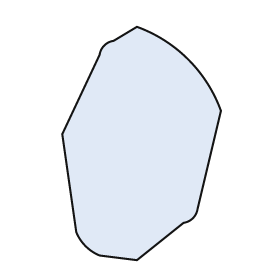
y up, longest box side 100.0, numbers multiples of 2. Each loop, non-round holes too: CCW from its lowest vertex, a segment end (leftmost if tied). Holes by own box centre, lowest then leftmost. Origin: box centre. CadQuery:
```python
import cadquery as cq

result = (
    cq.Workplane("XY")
    .moveTo(-2.0, -50.0)
    .lineTo(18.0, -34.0)
    .threePointArc((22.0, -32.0), (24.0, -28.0))
    .lineTo(34.0, 14.0)
    .threePointArc((20.0, 36.0), (-2.0, 50.0))
    .lineTo(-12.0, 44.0)
    .threePointArc((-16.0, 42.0), (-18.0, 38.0))
    .lineTo(-34.0, 4.0)
    .lineTo(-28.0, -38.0)
    .threePointArc((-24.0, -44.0), (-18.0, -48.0))
    .close()
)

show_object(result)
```